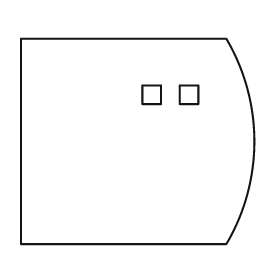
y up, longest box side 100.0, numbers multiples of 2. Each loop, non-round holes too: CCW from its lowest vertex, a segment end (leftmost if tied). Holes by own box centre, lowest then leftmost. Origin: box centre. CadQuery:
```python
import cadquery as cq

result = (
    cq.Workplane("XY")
    .moveTo(-50.0, -44.0)
    .lineTo(38.0, -44.0)
    .threePointArc((50.0, 0.0), (38.0, 44.0))
    .lineTo(-50.0, 44.0)
    .close()
    .moveTo(2.0, 16.0)
    .lineTo(10.0, 16.0)
    .lineTo(10.0, 24.0)
    .lineTo(2.0, 24.0)
    .close()
    .moveTo(18.0, 16.0)
    .lineTo(26.0, 16.0)
    .lineTo(26.0, 24.0)
    .lineTo(18.0, 24.0)
    .close()
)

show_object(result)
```